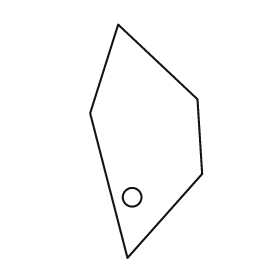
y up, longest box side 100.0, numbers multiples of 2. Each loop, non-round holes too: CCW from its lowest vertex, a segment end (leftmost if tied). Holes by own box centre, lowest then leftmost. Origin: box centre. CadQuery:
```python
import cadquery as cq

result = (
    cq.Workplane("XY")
    .moveTo(-8.0, -50.0)
    .lineTo(24.0, -14.0)
    .lineTo(22.0, 18.0)
    .lineTo(-12.0, 50.0)
    .lineTo(-24.0, 12.0)
    .close()
    .moveTo(-6.0, -24.0)
    .circle(4.0)
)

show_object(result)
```